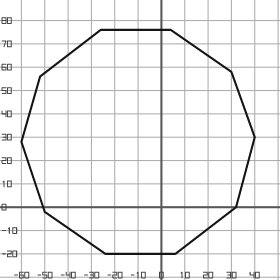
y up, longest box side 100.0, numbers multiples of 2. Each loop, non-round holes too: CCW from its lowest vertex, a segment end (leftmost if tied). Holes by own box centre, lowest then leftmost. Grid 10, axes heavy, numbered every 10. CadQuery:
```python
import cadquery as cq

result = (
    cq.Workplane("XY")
    .moveTo(-24.0, -20.0)
    .lineTo(6.0, -20.0)
    .lineTo(32.0, 0.0)
    .lineTo(40.0, 30.0)
    .lineTo(30.0, 58.0)
    .lineTo(4.0, 76.0)
    .lineTo(-26.0, 76.0)
    .lineTo(-52.0, 56.0)
    .lineTo(-60.0, 28.0)
    .lineTo(-50.0, -2.0)
    .close()
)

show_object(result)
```